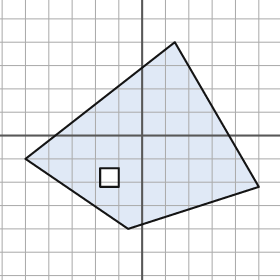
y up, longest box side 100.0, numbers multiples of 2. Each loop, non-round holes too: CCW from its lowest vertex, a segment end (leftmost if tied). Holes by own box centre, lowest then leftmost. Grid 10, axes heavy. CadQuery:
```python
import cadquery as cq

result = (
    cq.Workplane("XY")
    .moveTo(-6.0, -40.0)
    .lineTo(50.0, -22.0)
    .lineTo(14.0, 40.0)
    .lineTo(-50.0, -10.0)
    .close()
    .moveTo(-18.0, -22.0)
    .lineTo(-10.0, -22.0)
    .lineTo(-10.0, -14.0)
    .lineTo(-18.0, -14.0)
    .close()
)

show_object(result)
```